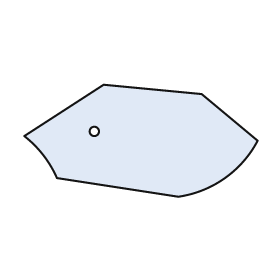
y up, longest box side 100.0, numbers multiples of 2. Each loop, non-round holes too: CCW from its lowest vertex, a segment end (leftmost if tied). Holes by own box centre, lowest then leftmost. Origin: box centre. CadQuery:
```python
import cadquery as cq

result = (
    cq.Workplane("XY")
    .moveTo(16.0, -24.0)
    .threePointArc((36.0, -16.0), (50.0, 0.0))
    .lineTo(26.0, 20.0)
    .lineTo(-16.0, 24.0)
    .lineTo(-50.0, 2.0)
    .threePointArc((-42.0, -6.0), (-36.0, -16.0))
    .close()
    .moveTo(-20.0, 4.0)
    .circle(2.0)
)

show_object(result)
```